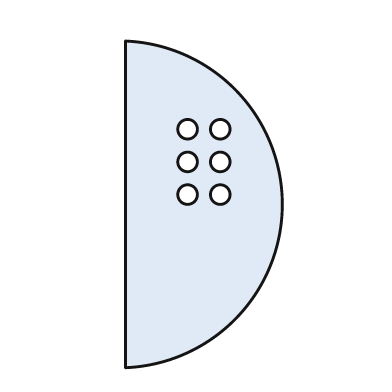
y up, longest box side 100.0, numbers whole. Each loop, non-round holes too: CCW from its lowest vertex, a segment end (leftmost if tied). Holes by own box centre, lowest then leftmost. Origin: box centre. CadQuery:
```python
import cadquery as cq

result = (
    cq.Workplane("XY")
    .moveTo(-24.0, -50.0)
    .threePointArc((24.0, 0.0), (-24.0, 50.0))
    .close()
    .moveTo(-5.0, 3.0)
    .circle(3.0)
    .moveTo(5.0, 3.0)
    .circle(3.0)
    .moveTo(-5.0, 13.0)
    .circle(3.0)
    .moveTo(5.0, 13.0)
    .circle(3.0)
    .moveTo(-5.0, 23.0)
    .circle(3.0)
    .moveTo(5.0, 23.0)
    .circle(3.0)
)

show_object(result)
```